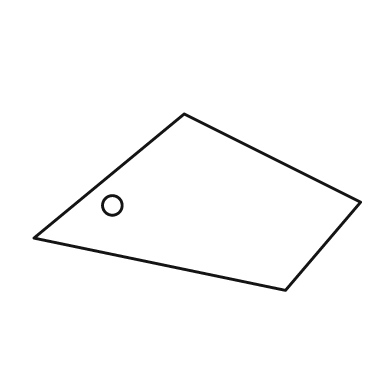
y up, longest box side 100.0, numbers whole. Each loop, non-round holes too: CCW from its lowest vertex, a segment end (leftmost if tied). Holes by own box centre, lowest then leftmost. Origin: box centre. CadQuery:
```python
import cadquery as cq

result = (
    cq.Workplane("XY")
    .moveTo(27.0, -27.0)
    .lineTo(50.0, 0.0)
    .lineTo(-4.0, 27.0)
    .lineTo(-50.0, -11.0)
    .close()
    .moveTo(-26.0, -1.0)
    .circle(3.0)
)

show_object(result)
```